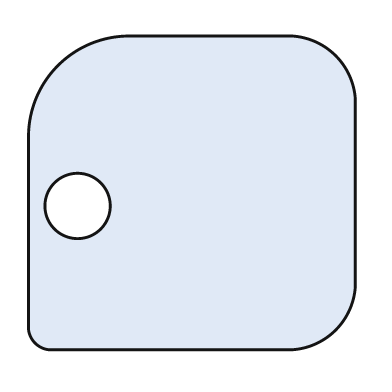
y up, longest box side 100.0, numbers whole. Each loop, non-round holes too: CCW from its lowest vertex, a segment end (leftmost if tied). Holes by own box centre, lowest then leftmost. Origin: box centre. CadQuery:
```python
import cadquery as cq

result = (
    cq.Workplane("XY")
    .moveTo(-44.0, -48.0)
    .lineTo(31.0, -48.0)
    .threePointArc((44.0, -42.0), (50.0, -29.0))
    .lineTo(50.0, 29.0)
    .threePointArc((44.0, 42.0), (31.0, 48.0))
    .lineTo(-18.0, 48.0)
    .threePointArc((-41.0, 39.0), (-50.0, 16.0))
    .lineTo(-50.0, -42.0)
    .threePointArc((-48.0, -46.0), (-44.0, -48.0))
    .close()
    .moveTo(-35.0, -4.0)
    .circle(10.0)
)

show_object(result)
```